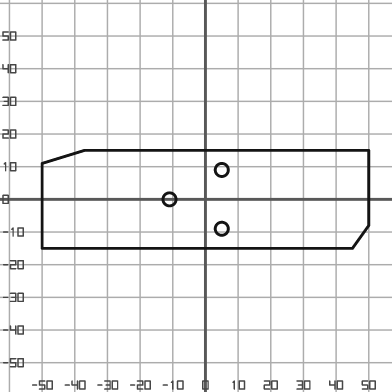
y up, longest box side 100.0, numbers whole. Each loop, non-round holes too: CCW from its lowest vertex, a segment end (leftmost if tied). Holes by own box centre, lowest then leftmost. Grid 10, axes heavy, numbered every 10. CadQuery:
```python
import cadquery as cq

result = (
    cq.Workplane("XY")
    .moveTo(-50.0, -15.0)
    .lineTo(45.0, -15.0)
    .lineTo(50.0, -8.0)
    .lineTo(50.0, 15.0)
    .lineTo(-37.0, 15.0)
    .lineTo(-50.0, 11.0)
    .close()
    .moveTo(5.0, -9.0)
    .circle(2.0)
    .moveTo(-11.0, 0.0)
    .circle(2.0)
    .moveTo(5.0, 9.0)
    .circle(2.0)
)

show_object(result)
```